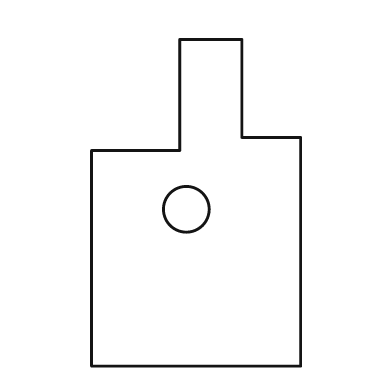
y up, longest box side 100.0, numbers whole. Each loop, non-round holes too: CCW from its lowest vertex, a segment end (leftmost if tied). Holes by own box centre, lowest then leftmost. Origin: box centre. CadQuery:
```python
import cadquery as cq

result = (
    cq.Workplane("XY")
    .moveTo(-32.0, -50.0)
    .lineTo(32.0, -50.0)
    .lineTo(32.0, 20.0)
    .lineTo(14.0, 20.0)
    .lineTo(14.0, 50.0)
    .lineTo(-5.0, 50.0)
    .lineTo(-5.0, 16.0)
    .lineTo(-32.0, 16.0)
    .close()
    .moveTo(-3.0, -2.0)
    .circle(7.0)
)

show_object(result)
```